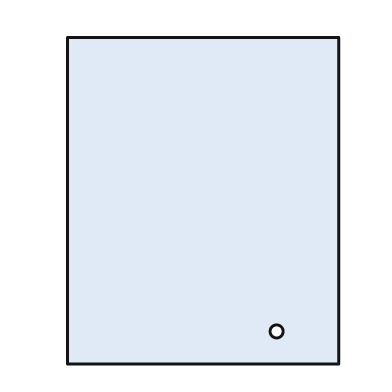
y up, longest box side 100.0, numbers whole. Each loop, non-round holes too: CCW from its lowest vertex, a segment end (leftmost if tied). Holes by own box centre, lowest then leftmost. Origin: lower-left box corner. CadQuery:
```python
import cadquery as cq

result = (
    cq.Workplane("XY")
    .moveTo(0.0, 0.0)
    .lineTo(83.0, 0.0)
    .lineTo(83.0, 100.0)
    .lineTo(0.0, 100.0)
    .close()
    .moveTo(64.0, 10.0)
    .circle(2.0)
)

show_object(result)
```